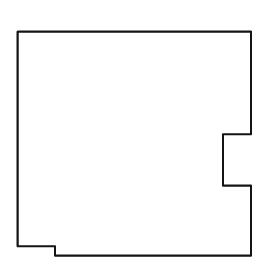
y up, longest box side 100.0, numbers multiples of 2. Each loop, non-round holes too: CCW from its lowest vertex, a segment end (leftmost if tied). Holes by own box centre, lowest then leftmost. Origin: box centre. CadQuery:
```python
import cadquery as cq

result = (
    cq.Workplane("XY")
    .moveTo(-34.0, -48.0)
    .lineTo(50.0, -48.0)
    .lineTo(50.0, -18.0)
    .lineTo(38.0, -18.0)
    .lineTo(38.0, 4.0)
    .lineTo(50.0, 4.0)
    .lineTo(50.0, 48.0)
    .lineTo(-50.0, 48.0)
    .lineTo(-50.0, -44.0)
    .lineTo(-34.0, -44.0)
    .close()
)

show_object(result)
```